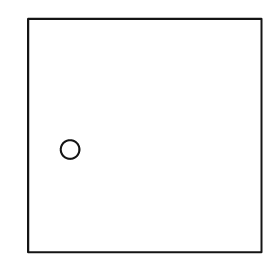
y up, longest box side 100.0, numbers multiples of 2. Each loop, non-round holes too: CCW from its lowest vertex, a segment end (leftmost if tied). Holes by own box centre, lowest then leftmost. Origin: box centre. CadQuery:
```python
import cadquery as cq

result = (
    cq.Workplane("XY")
    .moveTo(-50.0, -50.0)
    .lineTo(50.0, -50.0)
    .lineTo(50.0, 50.0)
    .lineTo(-50.0, 50.0)
    .close()
    .moveTo(-32.0, -6.0)
    .circle(4.0)
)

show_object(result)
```